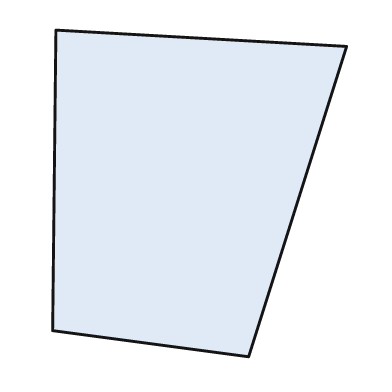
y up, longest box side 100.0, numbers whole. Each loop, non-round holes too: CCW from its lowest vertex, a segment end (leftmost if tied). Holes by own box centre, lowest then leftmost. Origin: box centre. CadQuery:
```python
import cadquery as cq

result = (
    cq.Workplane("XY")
    .moveTo(15.0, -50.0)
    .lineTo(45.0, 45.0)
    .lineTo(-44.0, 50.0)
    .lineTo(-45.0, -42.0)
    .close()
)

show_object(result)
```